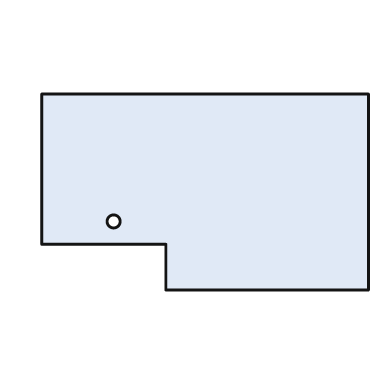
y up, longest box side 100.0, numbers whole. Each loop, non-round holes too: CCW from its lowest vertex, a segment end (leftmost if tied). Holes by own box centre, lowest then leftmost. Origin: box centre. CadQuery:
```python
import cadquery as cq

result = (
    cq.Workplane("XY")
    .moveTo(-12.0, -30.0)
    .lineTo(50.0, -30.0)
    .lineTo(50.0, 30.0)
    .lineTo(-50.0, 30.0)
    .lineTo(-50.0, -16.0)
    .lineTo(-12.0, -16.0)
    .close()
    .moveTo(-28.0, -9.0)
    .circle(2.0)
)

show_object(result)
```